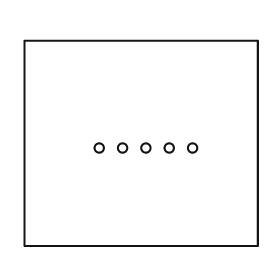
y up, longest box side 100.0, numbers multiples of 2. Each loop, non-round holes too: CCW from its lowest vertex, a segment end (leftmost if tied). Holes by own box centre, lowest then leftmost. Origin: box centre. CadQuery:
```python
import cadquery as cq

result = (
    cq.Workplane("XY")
    .moveTo(-50.0, -44.0)
    .lineTo(50.0, -44.0)
    .lineTo(50.0, 44.0)
    .lineTo(-50.0, 44.0)
    .close()
    .moveTo(-18.0, -2.0)
    .circle(2.0)
    .moveTo(-8.0, -2.0)
    .circle(2.0)
    .moveTo(2.0, -2.0)
    .circle(2.0)
    .moveTo(12.0, -2.0)
    .circle(2.0)
    .moveTo(22.0, -2.0)
    .circle(2.0)
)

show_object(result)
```